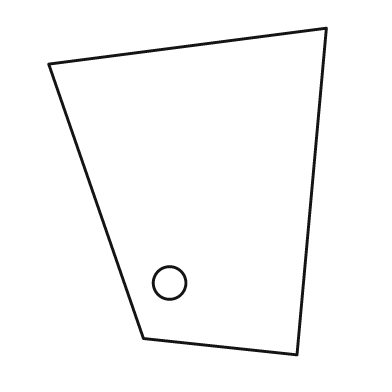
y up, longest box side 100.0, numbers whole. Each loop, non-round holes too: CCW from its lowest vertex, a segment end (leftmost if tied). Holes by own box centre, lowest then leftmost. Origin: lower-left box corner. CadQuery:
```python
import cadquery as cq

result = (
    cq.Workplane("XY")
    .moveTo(76.0, 0.0)
    .lineTo(85.0, 100.0)
    .lineTo(0.0, 89.0)
    .lineTo(29.0, 5.0)
    .close()
    .moveTo(37.0, 22.0)
    .circle(5.0)
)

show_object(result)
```